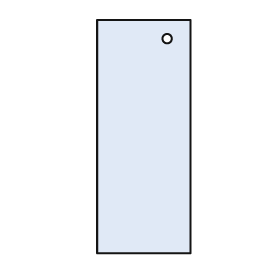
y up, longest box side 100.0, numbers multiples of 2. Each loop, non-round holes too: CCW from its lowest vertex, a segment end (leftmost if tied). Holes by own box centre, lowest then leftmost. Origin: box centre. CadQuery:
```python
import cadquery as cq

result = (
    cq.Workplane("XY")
    .moveTo(-20.0, -50.0)
    .lineTo(20.0, -50.0)
    .lineTo(20.0, 50.0)
    .lineTo(-20.0, 50.0)
    .close()
    .moveTo(10.0, 42.0)
    .circle(2.0)
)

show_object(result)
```